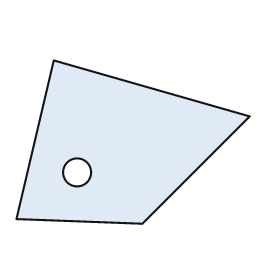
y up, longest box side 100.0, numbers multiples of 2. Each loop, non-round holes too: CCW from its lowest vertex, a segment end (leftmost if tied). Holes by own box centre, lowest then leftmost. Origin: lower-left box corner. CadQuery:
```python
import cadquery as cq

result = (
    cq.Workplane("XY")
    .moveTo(54.0, 0.0)
    .lineTo(100.0, 46.0)
    .lineTo(16.0, 70.0)
    .lineTo(0.0, 2.0)
    .close()
    .moveTo(26.0, 22.0)
    .circle(6.0)
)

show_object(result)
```